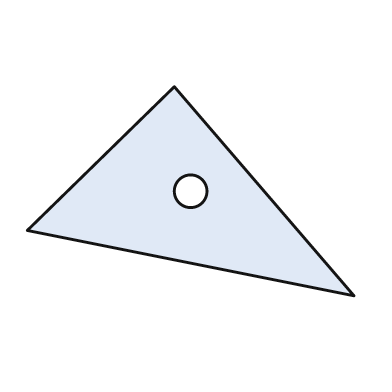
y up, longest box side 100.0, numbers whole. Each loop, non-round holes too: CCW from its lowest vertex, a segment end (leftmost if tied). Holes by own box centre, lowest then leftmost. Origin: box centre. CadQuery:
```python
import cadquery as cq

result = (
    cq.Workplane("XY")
    .moveTo(50.0, -32.0)
    .lineTo(-5.0, 32.0)
    .lineTo(-50.0, -12.0)
    .close()
    .moveTo(0.0, 0.0)
    .circle(5.0)
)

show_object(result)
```